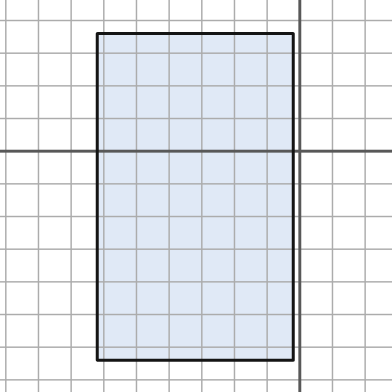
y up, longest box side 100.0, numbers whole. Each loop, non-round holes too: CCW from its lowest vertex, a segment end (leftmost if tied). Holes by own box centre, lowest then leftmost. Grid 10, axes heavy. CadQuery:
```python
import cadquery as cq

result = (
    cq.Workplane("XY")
    .moveTo(-62.0, -64.0)
    .lineTo(-2.0, -64.0)
    .lineTo(-2.0, 36.0)
    .lineTo(-62.0, 36.0)
    .close()
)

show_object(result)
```